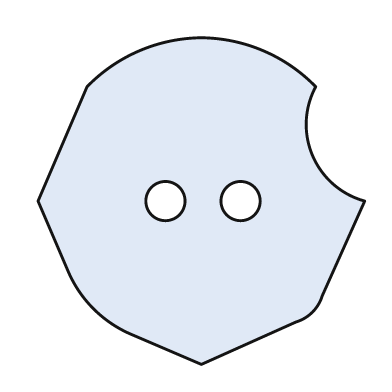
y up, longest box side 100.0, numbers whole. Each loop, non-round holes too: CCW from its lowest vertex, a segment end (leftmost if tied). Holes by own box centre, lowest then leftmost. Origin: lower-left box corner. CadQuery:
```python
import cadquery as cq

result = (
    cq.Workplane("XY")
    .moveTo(50.0, 0.0)
    .lineTo(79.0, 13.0)
    .threePointArc((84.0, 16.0), (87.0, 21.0))
    .lineTo(100.0, 50.0)
    .threePointArc((84.0, 64.0), (85.0, 85.0))
    .threePointArc((69.0, 96.0), (50.0, 100.0))
    .threePointArc((31.0, 96.0), (15.0, 85.0))
    .lineTo(0.0, 50.0)
    .lineTo(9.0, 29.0)
    .threePointArc((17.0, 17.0), (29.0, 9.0))
    .close()
    .moveTo(39.0, 50.0)
    .circle(6.0)
    .moveTo(62.0, 50.0)
    .circle(6.0)
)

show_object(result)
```